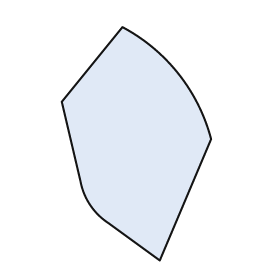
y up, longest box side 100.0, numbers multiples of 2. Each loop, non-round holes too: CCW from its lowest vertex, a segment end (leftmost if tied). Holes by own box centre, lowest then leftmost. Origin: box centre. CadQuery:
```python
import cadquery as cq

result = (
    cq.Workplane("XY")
    .moveTo(10.0, -50.0)
    .lineTo(32.0, 2.0)
    .threePointArc((18.0, 30.0), (-6.0, 50.0))
    .lineTo(-32.0, 18.0)
    .lineTo(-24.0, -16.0)
    .threePointArc((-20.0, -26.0), (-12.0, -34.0))
    .close()
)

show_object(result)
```